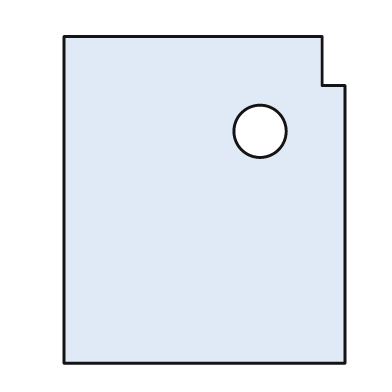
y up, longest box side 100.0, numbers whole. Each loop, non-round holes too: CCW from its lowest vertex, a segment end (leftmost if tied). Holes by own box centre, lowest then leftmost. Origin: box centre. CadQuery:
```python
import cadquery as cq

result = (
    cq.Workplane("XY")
    .moveTo(-43.0, -50.0)
    .lineTo(43.0, -50.0)
    .lineTo(43.0, 35.0)
    .lineTo(36.0, 35.0)
    .lineTo(36.0, 50.0)
    .lineTo(-43.0, 50.0)
    .close()
    .moveTo(17.0, 21.0)
    .circle(8.0)
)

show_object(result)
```